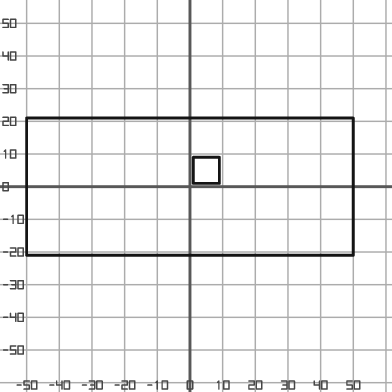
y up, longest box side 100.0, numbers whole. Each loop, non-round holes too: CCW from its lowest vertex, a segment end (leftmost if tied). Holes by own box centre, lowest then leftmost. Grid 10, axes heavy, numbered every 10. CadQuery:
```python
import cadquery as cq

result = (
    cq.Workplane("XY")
    .moveTo(-50.0, -21.0)
    .lineTo(50.0, -21.0)
    .lineTo(50.0, 21.0)
    .lineTo(-50.0, 21.0)
    .close()
    .moveTo(1.0, 1.0)
    .lineTo(9.0, 1.0)
    .lineTo(9.0, 9.0)
    .lineTo(1.0, 9.0)
    .close()
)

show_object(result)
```